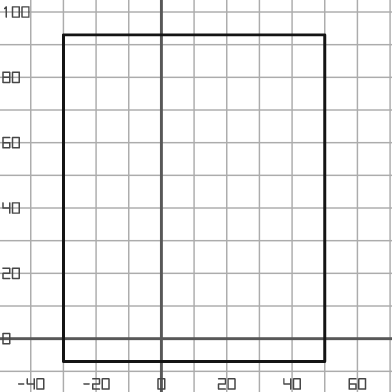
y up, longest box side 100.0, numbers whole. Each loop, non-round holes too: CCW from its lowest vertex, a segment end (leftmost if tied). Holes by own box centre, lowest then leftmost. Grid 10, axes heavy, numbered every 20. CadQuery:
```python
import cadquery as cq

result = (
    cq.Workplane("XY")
    .moveTo(-30.0, -7.0)
    .lineTo(50.0, -7.0)
    .lineTo(50.0, 93.0)
    .lineTo(-30.0, 93.0)
    .close()
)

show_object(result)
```